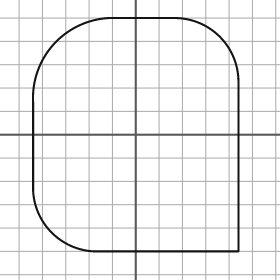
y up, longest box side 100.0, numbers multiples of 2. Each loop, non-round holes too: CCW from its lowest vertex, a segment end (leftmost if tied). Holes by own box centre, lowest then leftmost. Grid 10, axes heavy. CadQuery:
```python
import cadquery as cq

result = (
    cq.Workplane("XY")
    .moveTo(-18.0, -50.0)
    .lineTo(44.0, -50.0)
    .lineTo(44.0, 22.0)
    .threePointArc((36.0, 42.0), (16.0, 50.0))
    .lineTo(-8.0, 50.0)
    .threePointArc((-34.0, 40.0), (-44.0, 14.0))
    .lineTo(-44.0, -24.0)
    .threePointArc((-36.0, -42.0), (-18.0, -50.0))
    .close()
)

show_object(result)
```